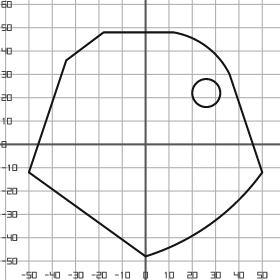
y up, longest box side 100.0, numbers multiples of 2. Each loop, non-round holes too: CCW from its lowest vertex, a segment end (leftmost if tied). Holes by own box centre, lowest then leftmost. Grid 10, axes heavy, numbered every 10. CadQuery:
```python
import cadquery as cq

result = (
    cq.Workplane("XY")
    .moveTo(0.0, -48.0)
    .threePointArc((28.0, -34.0), (50.0, -12.0))
    .lineTo(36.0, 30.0)
    .threePointArc((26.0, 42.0), (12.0, 48.0))
    .lineTo(-18.0, 48.0)
    .lineTo(-34.0, 36.0)
    .lineTo(-50.0, -12.0)
    .close()
    .moveTo(26.0, 22.0)
    .circle(6.0)
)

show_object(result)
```